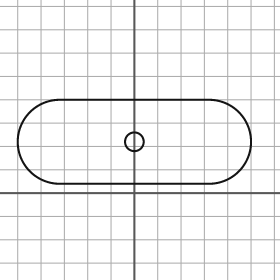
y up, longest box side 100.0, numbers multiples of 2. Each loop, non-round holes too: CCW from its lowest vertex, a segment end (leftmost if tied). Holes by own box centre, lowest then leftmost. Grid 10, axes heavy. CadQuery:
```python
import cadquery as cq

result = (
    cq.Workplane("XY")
    .moveTo(-32.0, 4.0)
    .lineTo(32.0, 4.0)
    .threePointArc((50.0, 22.0), (32.0, 40.0))
    .lineTo(-32.0, 40.0)
    .threePointArc((-50.0, 22.0), (-32.0, 4.0))
    .close()
    .moveTo(0.0, 22.0)
    .circle(4.0)
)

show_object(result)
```